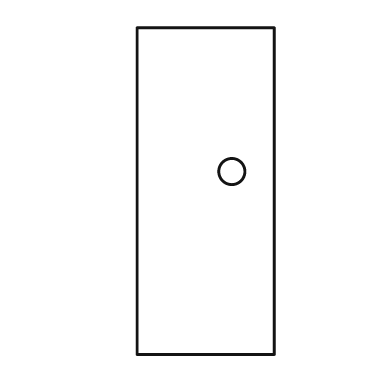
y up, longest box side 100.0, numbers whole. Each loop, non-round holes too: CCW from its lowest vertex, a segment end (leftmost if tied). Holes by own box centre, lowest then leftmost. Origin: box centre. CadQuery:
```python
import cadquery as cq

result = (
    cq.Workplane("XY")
    .moveTo(-21.0, -50.0)
    .lineTo(21.0, -50.0)
    .lineTo(21.0, 50.0)
    .lineTo(-21.0, 50.0)
    .close()
    .moveTo(8.0, 6.0)
    .circle(4.0)
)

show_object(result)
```